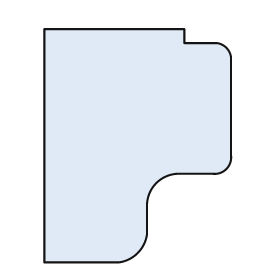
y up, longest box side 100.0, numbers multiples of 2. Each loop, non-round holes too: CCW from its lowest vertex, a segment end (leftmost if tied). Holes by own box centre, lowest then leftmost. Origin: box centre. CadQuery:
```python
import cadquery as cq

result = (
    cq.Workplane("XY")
    .moveTo(-40.0, -50.0)
    .lineTo(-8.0, -50.0)
    .threePointArc((0.0, -46.0), (4.0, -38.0))
    .lineTo(4.0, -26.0)
    .threePointArc((8.0, -16.0), (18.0, -12.0))
    .lineTo(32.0, -12.0)
    .threePointArc((38.0, -10.0), (40.0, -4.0))
    .lineTo(40.0, 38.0)
    .threePointArc((38.0, 42.0), (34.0, 44.0))
    .lineTo(20.0, 44.0)
    .lineTo(20.0, 50.0)
    .lineTo(-40.0, 50.0)
    .close()
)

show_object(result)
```